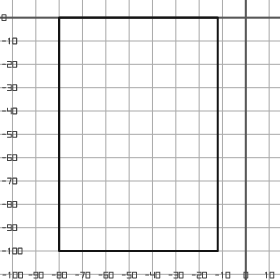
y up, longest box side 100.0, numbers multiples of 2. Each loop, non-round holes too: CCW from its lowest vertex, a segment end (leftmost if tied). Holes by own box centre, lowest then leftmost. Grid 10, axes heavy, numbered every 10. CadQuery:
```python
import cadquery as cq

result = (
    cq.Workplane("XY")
    .moveTo(-80.0, -100.0)
    .lineTo(-12.0, -100.0)
    .lineTo(-12.0, 0.0)
    .lineTo(-80.0, 0.0)
    .close()
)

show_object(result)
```